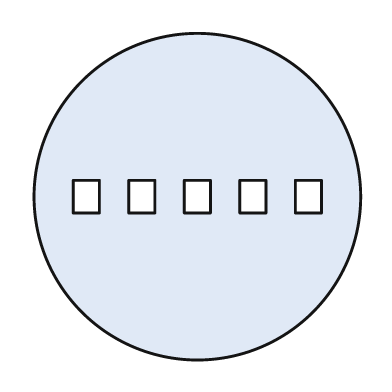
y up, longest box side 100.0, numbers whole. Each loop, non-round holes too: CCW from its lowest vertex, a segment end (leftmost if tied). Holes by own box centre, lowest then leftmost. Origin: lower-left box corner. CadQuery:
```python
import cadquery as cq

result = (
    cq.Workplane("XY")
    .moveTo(50.0, 50.0)
    .circle(50.0)
    .moveTo(12.0, 45.0)
    .lineTo(20.0, 45.0)
    .lineTo(20.0, 55.0)
    .lineTo(12.0, 55.0)
    .close()
    .moveTo(29.0, 45.0)
    .lineTo(37.0, 45.0)
    .lineTo(37.0, 55.0)
    .lineTo(29.0, 55.0)
    .close()
    .moveTo(46.0, 45.0)
    .lineTo(54.0, 45.0)
    .lineTo(54.0, 55.0)
    .lineTo(46.0, 55.0)
    .close()
    .moveTo(63.0, 45.0)
    .lineTo(71.0, 45.0)
    .lineTo(71.0, 55.0)
    .lineTo(63.0, 55.0)
    .close()
    .moveTo(80.0, 45.0)
    .lineTo(88.0, 45.0)
    .lineTo(88.0, 55.0)
    .lineTo(80.0, 55.0)
    .close()
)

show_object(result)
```